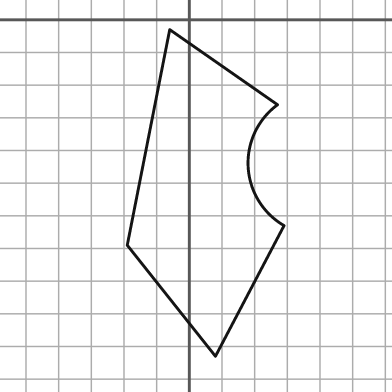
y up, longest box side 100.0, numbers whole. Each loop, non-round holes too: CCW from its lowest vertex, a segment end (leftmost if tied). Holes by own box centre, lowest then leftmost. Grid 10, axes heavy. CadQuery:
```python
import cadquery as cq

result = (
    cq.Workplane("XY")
    .moveTo(8.0, -103.0)
    .lineTo(29.0, -63.0)
    .threePointArc((18.0, -45.0), (27.0, -26.0))
    .lineTo(-6.0, -3.0)
    .lineTo(-19.0, -69.0)
    .close()
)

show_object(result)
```